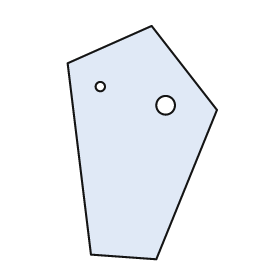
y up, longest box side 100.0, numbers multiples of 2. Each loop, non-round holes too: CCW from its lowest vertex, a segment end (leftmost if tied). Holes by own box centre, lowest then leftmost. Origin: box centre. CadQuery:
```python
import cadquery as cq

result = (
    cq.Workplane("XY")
    .moveTo(6.0, -50.0)
    .lineTo(32.0, 14.0)
    .lineTo(4.0, 50.0)
    .lineTo(-32.0, 34.0)
    .lineTo(-22.0, -48.0)
    .close()
    .moveTo(10.0, 16.0)
    .circle(4.0)
    .moveTo(-18.0, 24.0)
    .circle(2.0)
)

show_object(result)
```